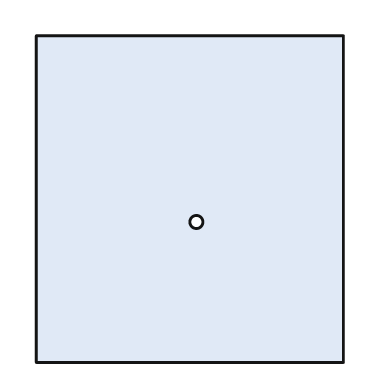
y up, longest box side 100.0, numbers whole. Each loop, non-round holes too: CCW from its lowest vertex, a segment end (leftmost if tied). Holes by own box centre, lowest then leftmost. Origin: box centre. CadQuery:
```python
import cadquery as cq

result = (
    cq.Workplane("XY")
    .moveTo(-47.0, -50.0)
    .lineTo(47.0, -50.0)
    .lineTo(47.0, 50.0)
    .lineTo(-47.0, 50.0)
    .close()
    .moveTo(2.0, -7.0)
    .circle(2.0)
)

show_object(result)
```